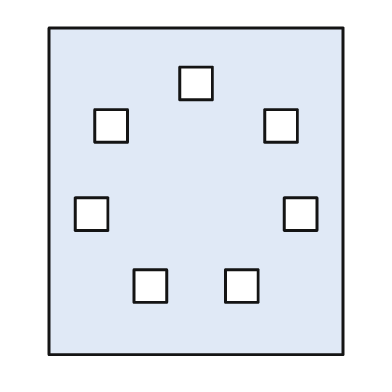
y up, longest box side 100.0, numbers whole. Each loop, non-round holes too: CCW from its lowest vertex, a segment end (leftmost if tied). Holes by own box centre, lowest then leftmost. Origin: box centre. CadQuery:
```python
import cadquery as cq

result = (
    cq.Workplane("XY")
    .moveTo(-45.0, -50.0)
    .lineTo(45.0, -50.0)
    .lineTo(45.0, 50.0)
    .lineTo(-45.0, 50.0)
    .close()
    .moveTo(-19.0, -34.0)
    .lineTo(-9.0, -34.0)
    .lineTo(-9.0, -24.0)
    .lineTo(-19.0, -24.0)
    .close()
    .moveTo(9.0, -34.0)
    .lineTo(19.0, -34.0)
    .lineTo(19.0, -24.0)
    .lineTo(9.0, -24.0)
    .close()
    .moveTo(-37.0, -12.0)
    .lineTo(-27.0, -12.0)
    .lineTo(-27.0, -2.0)
    .lineTo(-37.0, -2.0)
    .close()
    .moveTo(27.0, -12.0)
    .lineTo(37.0, -12.0)
    .lineTo(37.0, -2.0)
    .lineTo(27.0, -2.0)
    .close()
    .moveTo(-31.0, 15.0)
    .lineTo(-21.0, 15.0)
    .lineTo(-21.0, 25.0)
    .lineTo(-31.0, 25.0)
    .close()
    .moveTo(21.0, 15.0)
    .lineTo(31.0, 15.0)
    .lineTo(31.0, 25.0)
    .lineTo(21.0, 25.0)
    .close()
    .moveTo(-5.0, 28.0)
    .lineTo(5.0, 28.0)
    .lineTo(5.0, 38.0)
    .lineTo(-5.0, 38.0)
    .close()
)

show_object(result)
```